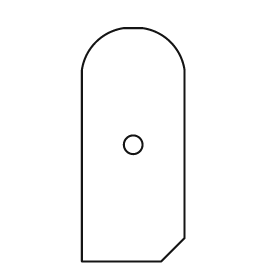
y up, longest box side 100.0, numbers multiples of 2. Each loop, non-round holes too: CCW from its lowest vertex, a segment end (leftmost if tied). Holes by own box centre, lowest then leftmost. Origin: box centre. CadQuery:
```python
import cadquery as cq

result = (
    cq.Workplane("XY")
    .moveTo(-22.0, -50.0)
    .lineTo(12.0, -50.0)
    .lineTo(22.0, -40.0)
    .lineTo(22.0, 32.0)
    .threePointArc((16.0, 44.0), (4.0, 50.0))
    .lineTo(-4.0, 50.0)
    .threePointArc((-16.0, 44.0), (-22.0, 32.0))
    .close()
    .moveTo(0.0, 0.0)
    .circle(4.0)
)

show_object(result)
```